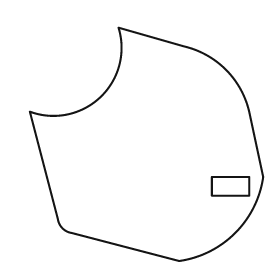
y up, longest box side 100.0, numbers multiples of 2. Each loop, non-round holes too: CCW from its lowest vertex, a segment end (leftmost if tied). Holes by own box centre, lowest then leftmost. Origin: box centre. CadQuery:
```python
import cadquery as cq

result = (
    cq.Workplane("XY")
    .moveTo(14.0, -50.0)
    .threePointArc((38.0, -38.0), (50.0, -14.0))
    .lineTo(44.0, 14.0)
    .threePointArc((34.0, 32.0), (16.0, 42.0))
    .lineTo(-12.0, 50.0)
    .threePointArc((-20.0, 20.0), (-50.0, 14.0))
    .lineTo(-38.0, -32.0)
    .threePointArc((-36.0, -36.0), (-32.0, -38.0))
    .close()
    .moveTo(28.0, -22.0)
    .lineTo(44.0, -22.0)
    .lineTo(44.0, -14.0)
    .lineTo(28.0, -14.0)
    .close()
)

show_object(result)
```